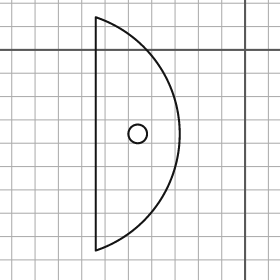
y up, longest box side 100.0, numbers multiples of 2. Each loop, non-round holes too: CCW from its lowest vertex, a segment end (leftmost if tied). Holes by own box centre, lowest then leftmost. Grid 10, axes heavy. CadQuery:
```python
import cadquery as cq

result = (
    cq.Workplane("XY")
    .moveTo(-64.0, -86.0)
    .threePointArc((-28.0, -36.0), (-64.0, 14.0))
    .close()
    .moveTo(-46.0, -36.0)
    .circle(4.0)
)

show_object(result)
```